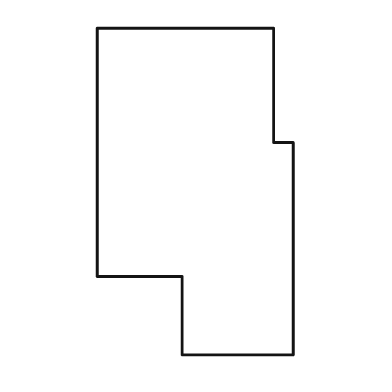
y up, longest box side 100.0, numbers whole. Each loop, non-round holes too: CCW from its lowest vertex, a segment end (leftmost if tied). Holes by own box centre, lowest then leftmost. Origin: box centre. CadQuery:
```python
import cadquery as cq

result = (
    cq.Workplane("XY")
    .moveTo(-4.0, -50.0)
    .lineTo(30.0, -50.0)
    .lineTo(30.0, 15.0)
    .lineTo(24.0, 15.0)
    .lineTo(24.0, 50.0)
    .lineTo(-30.0, 50.0)
    .lineTo(-30.0, -26.0)
    .lineTo(-4.0, -26.0)
    .close()
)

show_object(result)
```